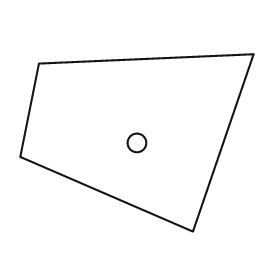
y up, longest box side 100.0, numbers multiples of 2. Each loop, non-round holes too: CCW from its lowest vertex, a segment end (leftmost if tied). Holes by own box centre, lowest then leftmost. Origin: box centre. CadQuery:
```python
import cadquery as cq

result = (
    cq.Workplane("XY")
    .moveTo(24.0, -38.0)
    .lineTo(50.0, 38.0)
    .lineTo(-42.0, 34.0)
    .lineTo(-50.0, -6.0)
    .close()
    .moveTo(0.0, 0.0)
    .circle(4.0)
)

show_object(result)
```